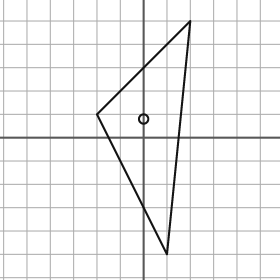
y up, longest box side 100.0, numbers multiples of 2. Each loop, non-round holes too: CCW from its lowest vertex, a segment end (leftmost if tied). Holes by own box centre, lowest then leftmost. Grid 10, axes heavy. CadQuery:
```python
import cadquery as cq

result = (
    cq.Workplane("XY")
    .moveTo(10.0, -50.0)
    .lineTo(20.0, 50.0)
    .lineTo(-20.0, 10.0)
    .close()
    .moveTo(0.0, 8.0)
    .circle(2.0)
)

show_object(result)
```